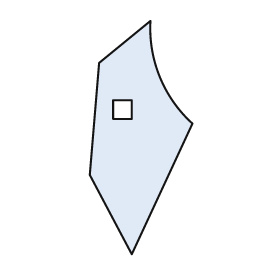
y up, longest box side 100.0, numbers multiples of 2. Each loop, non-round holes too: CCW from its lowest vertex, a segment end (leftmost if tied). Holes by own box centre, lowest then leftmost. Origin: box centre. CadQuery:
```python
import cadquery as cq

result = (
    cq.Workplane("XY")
    .moveTo(-4.0, -50.0)
    .lineTo(22.0, 6.0)
    .threePointArc((8.0, 26.0), (4.0, 50.0))
    .lineTo(-18.0, 32.0)
    .lineTo(-22.0, -16.0)
    .close()
    .moveTo(-12.0, 8.0)
    .lineTo(-4.0, 8.0)
    .lineTo(-4.0, 16.0)
    .lineTo(-12.0, 16.0)
    .close()
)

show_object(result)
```